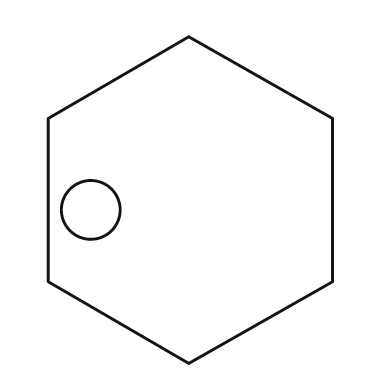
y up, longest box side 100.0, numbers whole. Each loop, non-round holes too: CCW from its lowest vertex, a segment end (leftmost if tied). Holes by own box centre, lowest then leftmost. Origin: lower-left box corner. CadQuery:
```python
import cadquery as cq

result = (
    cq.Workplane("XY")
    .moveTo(43.0, 0.0)
    .lineTo(87.0, 25.0)
    .lineTo(87.0, 75.0)
    .lineTo(43.0, 100.0)
    .lineTo(0.0, 75.0)
    .lineTo(0.0, 25.0)
    .close()
    .moveTo(13.0, 47.0)
    .circle(9.0)
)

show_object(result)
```